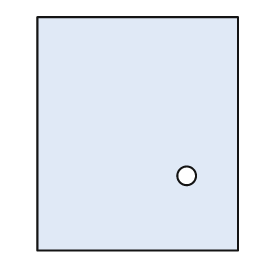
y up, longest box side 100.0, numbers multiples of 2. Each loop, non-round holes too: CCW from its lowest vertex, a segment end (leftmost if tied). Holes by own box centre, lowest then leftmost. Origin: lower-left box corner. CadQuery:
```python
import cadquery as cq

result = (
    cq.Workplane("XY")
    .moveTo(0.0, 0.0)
    .lineTo(86.0, 0.0)
    .lineTo(86.0, 100.0)
    .lineTo(0.0, 100.0)
    .close()
    .moveTo(64.0, 32.0)
    .circle(4.0)
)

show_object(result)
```